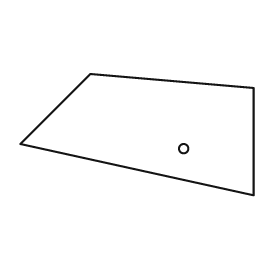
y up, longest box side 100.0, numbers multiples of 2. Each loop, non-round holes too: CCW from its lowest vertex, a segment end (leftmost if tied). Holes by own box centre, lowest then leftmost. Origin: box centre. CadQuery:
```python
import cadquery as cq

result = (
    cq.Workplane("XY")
    .moveTo(50.0, -26.0)
    .lineTo(50.0, 20.0)
    .lineTo(-20.0, 26.0)
    .lineTo(-50.0, -4.0)
    .close()
    .moveTo(20.0, -6.0)
    .circle(2.0)
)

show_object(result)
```